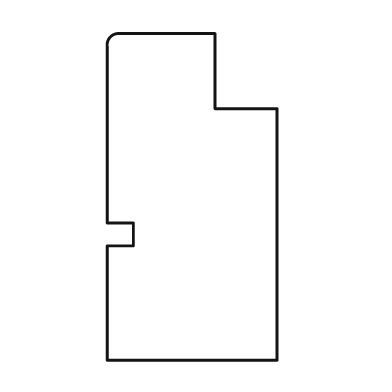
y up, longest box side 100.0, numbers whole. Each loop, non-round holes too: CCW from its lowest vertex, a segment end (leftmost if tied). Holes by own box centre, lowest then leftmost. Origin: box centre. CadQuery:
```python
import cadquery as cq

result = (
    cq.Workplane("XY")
    .moveTo(-26.0, -50.0)
    .lineTo(26.0, -50.0)
    .lineTo(26.0, 27.0)
    .lineTo(7.0, 27.0)
    .lineTo(7.0, 50.0)
    .lineTo(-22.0, 50.0)
    .threePointArc((-25.0, 49.0), (-26.0, 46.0))
    .lineTo(-26.0, -8.0)
    .lineTo(-18.0, -8.0)
    .lineTo(-18.0, -15.0)
    .lineTo(-26.0, -15.0)
    .close()
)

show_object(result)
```